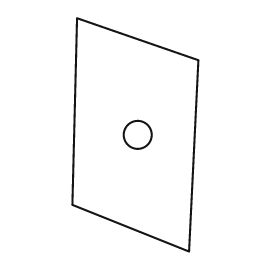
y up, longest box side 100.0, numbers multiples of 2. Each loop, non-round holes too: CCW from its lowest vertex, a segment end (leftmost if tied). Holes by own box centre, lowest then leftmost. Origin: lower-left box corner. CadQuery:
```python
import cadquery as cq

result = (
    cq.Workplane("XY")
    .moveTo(50.0, 0.0)
    .lineTo(54.0, 82.0)
    .lineTo(2.0, 100.0)
    .lineTo(0.0, 20.0)
    .close()
    .moveTo(28.0, 50.0)
    .circle(6.0)
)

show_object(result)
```